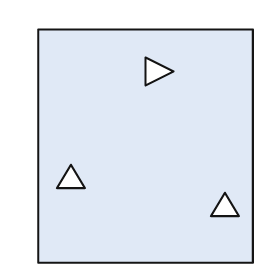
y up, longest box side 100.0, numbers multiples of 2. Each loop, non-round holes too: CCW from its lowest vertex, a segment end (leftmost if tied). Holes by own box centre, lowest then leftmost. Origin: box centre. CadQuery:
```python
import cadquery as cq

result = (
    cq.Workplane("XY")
    .moveTo(-46.0, -50.0)
    .lineTo(46.0, -50.0)
    .lineTo(46.0, 50.0)
    .lineTo(-46.0, 50.0)
    .close()
    .moveTo(28.0, -30.0)
    .lineTo(40.0, -30.0)
    .lineTo(34.0, -20.0)
    .close()
    .moveTo(-38.0, -18.0)
    .lineTo(-26.0, -18.0)
    .lineTo(-32.0, -8.0)
    .close()
    .moveTo(0.0, 26.0)
    .lineTo(12.0, 32.0)
    .lineTo(0.0, 38.0)
    .close()
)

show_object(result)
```